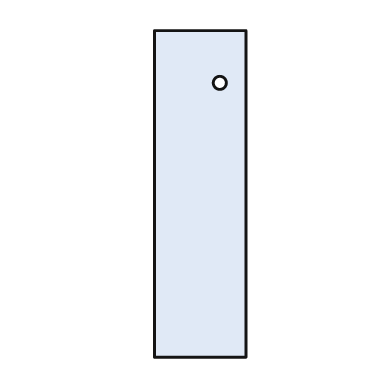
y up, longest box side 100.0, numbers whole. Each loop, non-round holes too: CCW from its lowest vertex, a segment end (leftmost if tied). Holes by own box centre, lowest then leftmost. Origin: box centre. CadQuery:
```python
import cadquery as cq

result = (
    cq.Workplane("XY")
    .moveTo(-14.0, -50.0)
    .lineTo(14.0, -50.0)
    .lineTo(14.0, 50.0)
    .lineTo(-14.0, 50.0)
    .close()
    .moveTo(6.0, 34.0)
    .circle(2.0)
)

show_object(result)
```